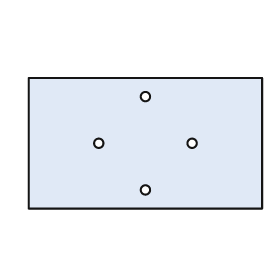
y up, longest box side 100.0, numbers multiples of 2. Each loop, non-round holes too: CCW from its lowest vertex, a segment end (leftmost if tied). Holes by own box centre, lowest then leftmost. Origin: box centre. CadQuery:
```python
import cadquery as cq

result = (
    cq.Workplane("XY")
    .moveTo(-50.0, -28.0)
    .lineTo(50.0, -28.0)
    .lineTo(50.0, 28.0)
    .lineTo(-50.0, 28.0)
    .close()
    .moveTo(0.0, -20.0)
    .circle(2.0)
    .moveTo(-20.0, 0.0)
    .circle(2.0)
    .moveTo(20.0, 0.0)
    .circle(2.0)
    .moveTo(0.0, 20.0)
    .circle(2.0)
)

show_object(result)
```